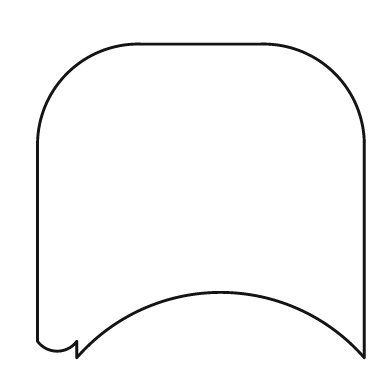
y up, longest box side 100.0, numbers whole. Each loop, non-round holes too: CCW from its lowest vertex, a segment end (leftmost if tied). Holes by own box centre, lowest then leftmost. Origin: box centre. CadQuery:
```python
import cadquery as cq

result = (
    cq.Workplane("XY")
    .moveTo(-38.0, -48.0)
    .threePointArc((6.0, -28.0), (50.0, -48.0))
    .lineTo(50.0, 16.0)
    .threePointArc((41.0, 39.0), (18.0, 48.0))
    .lineTo(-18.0, 48.0)
    .threePointArc((-41.0, 39.0), (-50.0, 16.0))
    .lineTo(-50.0, -43.0)
    .threePointArc((-44.0, -46.0), (-38.0, -43.0))
    .close()
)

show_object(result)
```